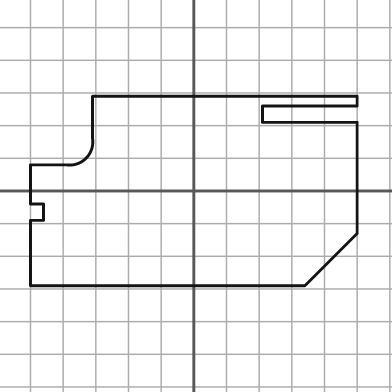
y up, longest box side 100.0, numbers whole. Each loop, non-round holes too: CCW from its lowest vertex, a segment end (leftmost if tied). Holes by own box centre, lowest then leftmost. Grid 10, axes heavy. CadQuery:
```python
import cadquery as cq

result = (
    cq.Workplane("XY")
    .moveTo(-50.0, -29.0)
    .lineTo(34.0, -29.0)
    .lineTo(50.0, -13.0)
    .lineTo(50.0, 21.0)
    .lineTo(21.0, 21.0)
    .lineTo(21.0, 26.0)
    .lineTo(50.0, 26.0)
    .lineTo(50.0, 29.0)
    .lineTo(-31.0, 29.0)
    .lineTo(-31.0, 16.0)
    .threePointArc((-33.0, 10.0), (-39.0, 8.0))
    .lineTo(-50.0, 8.0)
    .lineTo(-50.0, -4.0)
    .lineTo(-46.0, -4.0)
    .lineTo(-46.0, -9.0)
    .lineTo(-50.0, -9.0)
    .close()
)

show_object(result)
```